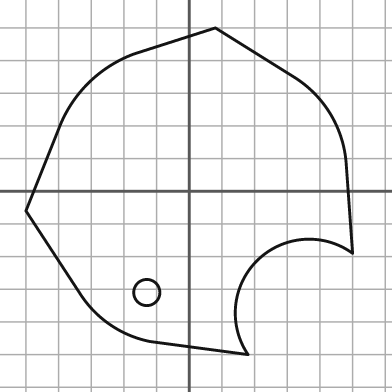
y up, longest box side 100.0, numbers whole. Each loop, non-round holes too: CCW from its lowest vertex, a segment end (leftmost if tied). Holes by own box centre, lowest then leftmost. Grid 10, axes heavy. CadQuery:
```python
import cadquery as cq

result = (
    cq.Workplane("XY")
    .moveTo(18.0, -50.0)
    .threePointArc((21.0, -21.0), (50.0, -19.0))
    .lineTo(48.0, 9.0)
    .threePointArc((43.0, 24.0), (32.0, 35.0))
    .lineTo(8.0, 50.0)
    .lineTo(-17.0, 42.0)
    .threePointArc((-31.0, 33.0), (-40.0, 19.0))
    .lineTo(-50.0, -6.0)
    .lineTo(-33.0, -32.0)
    .threePointArc((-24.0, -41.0), (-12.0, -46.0))
    .close()
    .moveTo(-13.0, -31.0)
    .circle(4.0)
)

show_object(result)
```